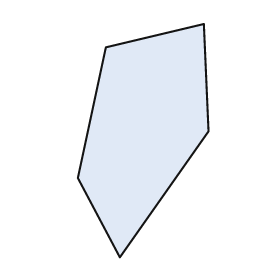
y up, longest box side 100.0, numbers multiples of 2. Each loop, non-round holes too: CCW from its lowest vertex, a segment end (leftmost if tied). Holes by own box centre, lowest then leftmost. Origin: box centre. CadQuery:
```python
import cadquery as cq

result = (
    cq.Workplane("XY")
    .moveTo(-10.0, -50.0)
    .lineTo(28.0, 4.0)
    .lineTo(26.0, 50.0)
    .lineTo(-16.0, 40.0)
    .lineTo(-28.0, -16.0)
    .close()
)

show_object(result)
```